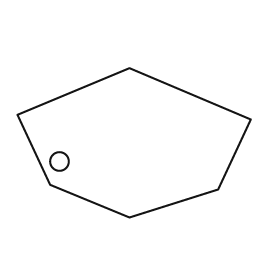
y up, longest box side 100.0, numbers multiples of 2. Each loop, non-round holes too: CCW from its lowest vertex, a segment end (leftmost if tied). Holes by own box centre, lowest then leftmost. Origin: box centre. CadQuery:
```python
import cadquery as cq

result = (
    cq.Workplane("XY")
    .moveTo(-2.0, -32.0)
    .lineTo(36.0, -20.0)
    .lineTo(50.0, 10.0)
    .lineTo(-2.0, 32.0)
    .lineTo(-50.0, 12.0)
    .lineTo(-36.0, -18.0)
    .close()
    .moveTo(-32.0, -8.0)
    .circle(4.0)
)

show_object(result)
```